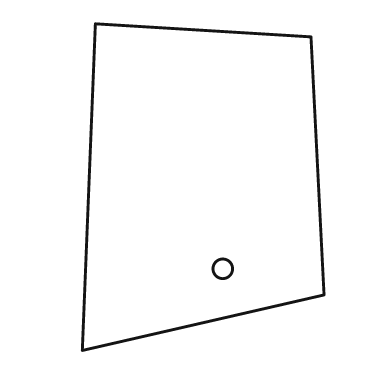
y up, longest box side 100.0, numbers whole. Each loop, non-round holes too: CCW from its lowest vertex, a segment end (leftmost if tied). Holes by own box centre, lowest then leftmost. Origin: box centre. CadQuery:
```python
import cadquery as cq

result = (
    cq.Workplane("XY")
    .moveTo(-37.0, -50.0)
    .lineTo(37.0, -33.0)
    .lineTo(33.0, 46.0)
    .lineTo(-33.0, 50.0)
    .close()
    .moveTo(6.0, -25.0)
    .circle(3.0)
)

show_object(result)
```